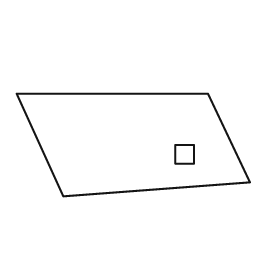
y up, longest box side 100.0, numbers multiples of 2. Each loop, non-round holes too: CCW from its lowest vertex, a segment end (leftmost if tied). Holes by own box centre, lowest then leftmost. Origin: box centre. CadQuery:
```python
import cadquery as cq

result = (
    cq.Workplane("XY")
    .moveTo(-30.0, -22.0)
    .lineTo(50.0, -16.0)
    .lineTo(32.0, 22.0)
    .lineTo(-50.0, 22.0)
    .close()
    .moveTo(18.0, -8.0)
    .lineTo(26.0, -8.0)
    .lineTo(26.0, 0.0)
    .lineTo(18.0, 0.0)
    .close()
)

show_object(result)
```